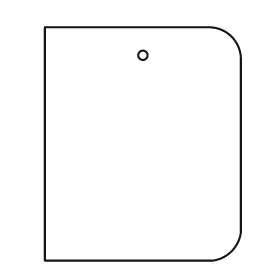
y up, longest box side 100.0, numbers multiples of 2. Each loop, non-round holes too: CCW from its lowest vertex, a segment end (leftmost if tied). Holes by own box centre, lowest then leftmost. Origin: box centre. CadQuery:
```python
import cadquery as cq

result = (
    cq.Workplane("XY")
    .moveTo(-42.0, -50.0)
    .lineTo(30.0, -50.0)
    .threePointArc((38.0, -46.0), (42.0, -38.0))
    .lineTo(42.0, 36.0)
    .threePointArc((38.0, 46.0), (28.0, 50.0))
    .lineTo(-42.0, 50.0)
    .close()
    .moveTo(0.0, 38.0)
    .circle(2.0)
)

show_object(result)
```